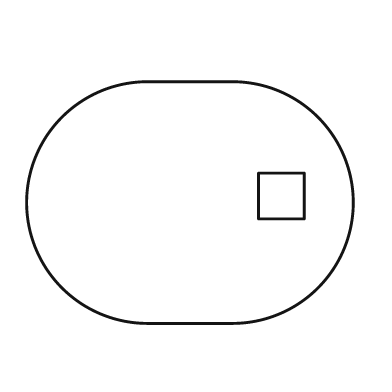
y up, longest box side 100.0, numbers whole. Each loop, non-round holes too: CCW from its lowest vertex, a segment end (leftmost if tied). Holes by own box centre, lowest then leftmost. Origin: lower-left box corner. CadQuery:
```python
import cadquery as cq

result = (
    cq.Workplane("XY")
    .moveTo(37.0, 0.0)
    .lineTo(63.0, 0.0)
    .threePointArc((100.0, 37.0), (63.0, 74.0))
    .lineTo(37.0, 74.0)
    .threePointArc((0.0, 37.0), (37.0, 0.0))
    .close()
    .moveTo(71.0, 32.0)
    .lineTo(85.0, 32.0)
    .lineTo(85.0, 46.0)
    .lineTo(71.0, 46.0)
    .close()
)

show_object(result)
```